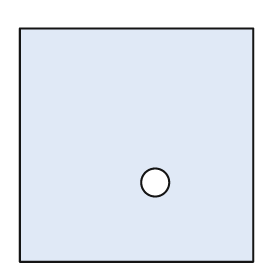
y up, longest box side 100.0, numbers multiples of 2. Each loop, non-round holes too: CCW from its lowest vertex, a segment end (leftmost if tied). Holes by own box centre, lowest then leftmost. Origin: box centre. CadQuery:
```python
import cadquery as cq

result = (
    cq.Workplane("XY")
    .moveTo(-50.0, -50.0)
    .lineTo(50.0, -50.0)
    .lineTo(50.0, 50.0)
    .lineTo(-50.0, 50.0)
    .close()
    .moveTo(8.0, -16.0)
    .circle(6.0)
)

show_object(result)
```